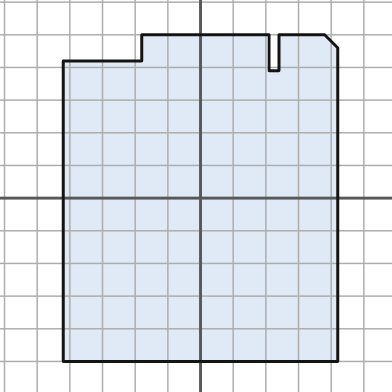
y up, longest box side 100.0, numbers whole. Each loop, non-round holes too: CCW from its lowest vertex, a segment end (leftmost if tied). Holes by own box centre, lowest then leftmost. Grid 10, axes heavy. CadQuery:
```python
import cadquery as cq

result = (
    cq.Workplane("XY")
    .moveTo(-42.0, -50.0)
    .lineTo(42.0, -50.0)
    .lineTo(42.0, 46.0)
    .lineTo(38.0, 50.0)
    .lineTo(24.0, 50.0)
    .lineTo(24.0, 39.0)
    .lineTo(21.0, 39.0)
    .lineTo(21.0, 50.0)
    .lineTo(-18.0, 50.0)
    .lineTo(-18.0, 42.0)
    .lineTo(-42.0, 42.0)
    .close()
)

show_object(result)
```